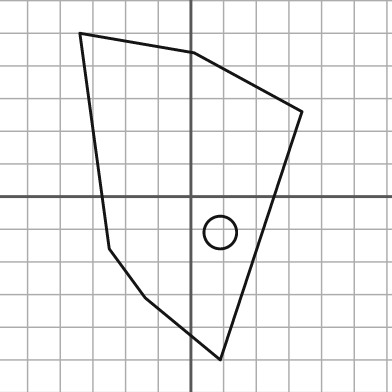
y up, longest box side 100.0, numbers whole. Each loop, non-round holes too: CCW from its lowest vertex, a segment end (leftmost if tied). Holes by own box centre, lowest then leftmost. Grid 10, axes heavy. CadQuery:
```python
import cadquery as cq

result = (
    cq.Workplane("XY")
    .moveTo(9.0, -50.0)
    .lineTo(34.0, 26.0)
    .lineTo(1.0, 44.0)
    .lineTo(-34.0, 50.0)
    .lineTo(-25.0, -16.0)
    .lineTo(-14.0, -31.0)
    .close()
    .moveTo(9.0, -11.0)
    .circle(5.0)
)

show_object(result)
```